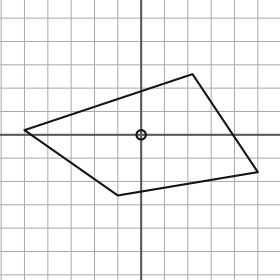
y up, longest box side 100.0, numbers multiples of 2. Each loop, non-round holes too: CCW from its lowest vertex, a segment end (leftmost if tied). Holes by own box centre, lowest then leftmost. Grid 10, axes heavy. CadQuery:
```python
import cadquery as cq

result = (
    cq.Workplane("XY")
    .moveTo(-10.0, -26.0)
    .lineTo(50.0, -16.0)
    .lineTo(22.0, 26.0)
    .lineTo(-50.0, 2.0)
    .close()
    .moveTo(0.0, 0.0)
    .circle(2.0)
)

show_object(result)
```